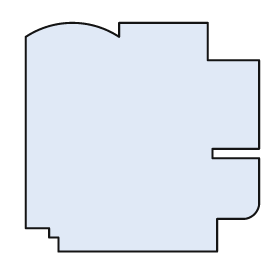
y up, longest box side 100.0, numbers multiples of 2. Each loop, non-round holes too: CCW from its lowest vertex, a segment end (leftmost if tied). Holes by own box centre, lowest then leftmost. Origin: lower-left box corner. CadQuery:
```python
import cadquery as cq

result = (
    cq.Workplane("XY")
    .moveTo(14.0, 0.0)
    .lineTo(82.0, 0.0)
    .lineTo(82.0, 14.0)
    .lineTo(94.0, 14.0)
    .threePointArc((98.0, 16.0), (100.0, 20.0))
    .lineTo(100.0, 40.0)
    .lineTo(80.0, 40.0)
    .lineTo(80.0, 44.0)
    .lineTo(100.0, 44.0)
    .lineTo(100.0, 82.0)
    .lineTo(78.0, 82.0)
    .lineTo(78.0, 98.0)
    .lineTo(40.0, 98.0)
    .lineTo(40.0, 92.0)
    .threePointArc((20.0, 98.0), (0.0, 92.0))
    .lineTo(0.0, 10.0)
    .lineTo(10.0, 10.0)
    .lineTo(10.0, 6.0)
    .lineTo(14.0, 6.0)
    .close()
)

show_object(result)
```